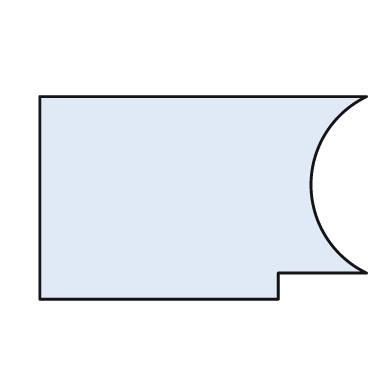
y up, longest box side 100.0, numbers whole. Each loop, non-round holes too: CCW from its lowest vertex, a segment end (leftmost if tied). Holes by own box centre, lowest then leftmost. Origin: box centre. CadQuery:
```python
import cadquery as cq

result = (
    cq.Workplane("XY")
    .moveTo(-50.0, -31.0)
    .lineTo(23.0, -31.0)
    .lineTo(23.0, -23.0)
    .lineTo(50.0, -23.0)
    .threePointArc((33.0, 4.0), (50.0, 31.0))
    .lineTo(-50.0, 31.0)
    .close()
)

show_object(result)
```